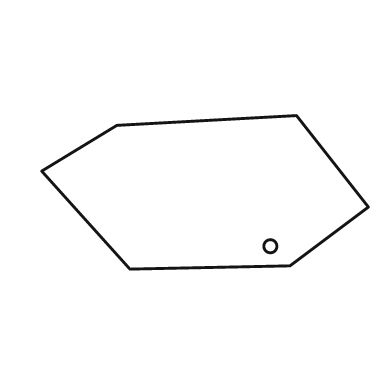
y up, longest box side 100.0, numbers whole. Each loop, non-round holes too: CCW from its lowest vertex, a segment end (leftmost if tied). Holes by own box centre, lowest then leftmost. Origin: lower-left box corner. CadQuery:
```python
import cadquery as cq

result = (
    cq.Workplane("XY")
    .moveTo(27.0, 0.0)
    .lineTo(76.0, 1.0)
    .lineTo(100.0, 19.0)
    .lineTo(78.0, 47.0)
    .lineTo(23.0, 44.0)
    .lineTo(0.0, 30.0)
    .close()
    .moveTo(70.0, 7.0)
    .circle(2.0)
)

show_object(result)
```